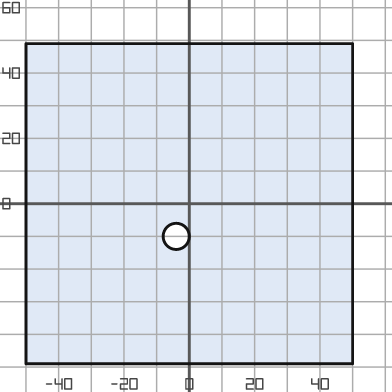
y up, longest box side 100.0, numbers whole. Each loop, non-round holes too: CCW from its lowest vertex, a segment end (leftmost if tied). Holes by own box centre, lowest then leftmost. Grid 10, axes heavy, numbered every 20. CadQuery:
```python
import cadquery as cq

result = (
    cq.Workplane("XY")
    .moveTo(-50.0, -49.0)
    .lineTo(50.0, -49.0)
    .lineTo(50.0, 49.0)
    .lineTo(-50.0, 49.0)
    .close()
    .moveTo(-4.0, -10.0)
    .circle(4.0)
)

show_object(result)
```